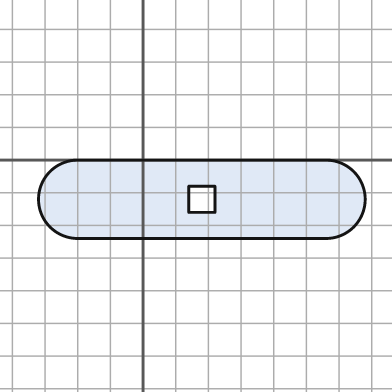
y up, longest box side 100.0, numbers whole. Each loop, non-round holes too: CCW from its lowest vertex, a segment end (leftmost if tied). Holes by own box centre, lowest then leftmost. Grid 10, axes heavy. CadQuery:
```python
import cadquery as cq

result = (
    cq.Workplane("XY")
    .moveTo(-20.0, -24.0)
    .lineTo(56.0, -24.0)
    .threePointArc((68.0, -12.0), (56.0, 0.0))
    .lineTo(-20.0, 0.0)
    .threePointArc((-32.0, -12.0), (-20.0, -24.0))
    .close()
    .moveTo(14.0, -16.0)
    .lineTo(22.0, -16.0)
    .lineTo(22.0, -8.0)
    .lineTo(14.0, -8.0)
    .close()
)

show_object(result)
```